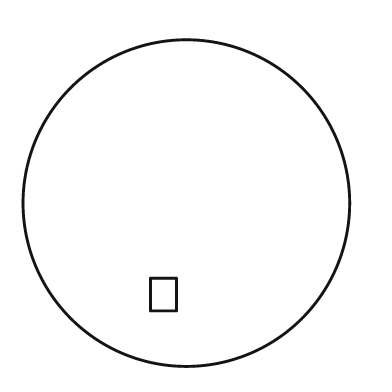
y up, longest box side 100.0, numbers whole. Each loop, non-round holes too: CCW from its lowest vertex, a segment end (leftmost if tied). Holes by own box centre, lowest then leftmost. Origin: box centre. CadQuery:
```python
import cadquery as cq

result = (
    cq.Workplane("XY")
    .moveTo(0.0, 0.0)
    .circle(50.0)
    .moveTo(-11.0, -33.0)
    .lineTo(-3.0, -33.0)
    .lineTo(-3.0, -23.0)
    .lineTo(-11.0, -23.0)
    .close()
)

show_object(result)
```